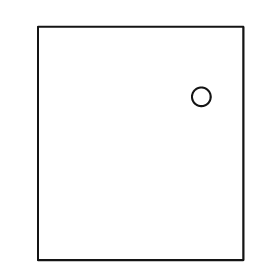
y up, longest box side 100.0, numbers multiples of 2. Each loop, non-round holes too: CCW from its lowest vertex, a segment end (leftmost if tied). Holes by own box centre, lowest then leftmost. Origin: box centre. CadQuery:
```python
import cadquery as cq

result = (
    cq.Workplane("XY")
    .moveTo(-44.0, -50.0)
    .lineTo(44.0, -50.0)
    .lineTo(44.0, 50.0)
    .lineTo(-44.0, 50.0)
    .close()
    .moveTo(26.0, 20.0)
    .circle(4.0)
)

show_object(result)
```